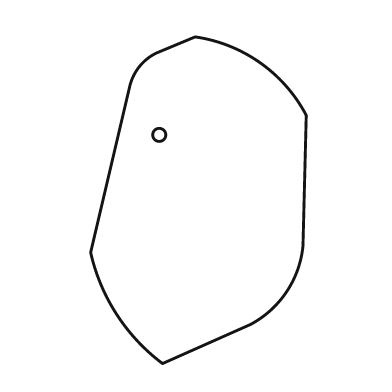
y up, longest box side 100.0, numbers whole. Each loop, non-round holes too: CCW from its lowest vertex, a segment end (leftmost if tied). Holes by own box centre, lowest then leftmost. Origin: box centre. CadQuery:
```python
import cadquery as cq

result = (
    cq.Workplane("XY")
    .moveTo(-11.0, -50.0)
    .lineTo(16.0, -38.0)
    .threePointArc((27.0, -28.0), (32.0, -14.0))
    .lineTo(33.0, 26.0)
    .threePointArc((19.0, 42.0), (-1.0, 50.0))
    .lineTo(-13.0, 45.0)
    .threePointArc((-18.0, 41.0), (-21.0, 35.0))
    .lineTo(-33.0, -16.0)
    .threePointArc((-25.0, -35.0), (-11.0, -50.0))
    .close()
    .moveTo(-12.0, 20.0)
    .circle(2.0)
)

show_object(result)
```